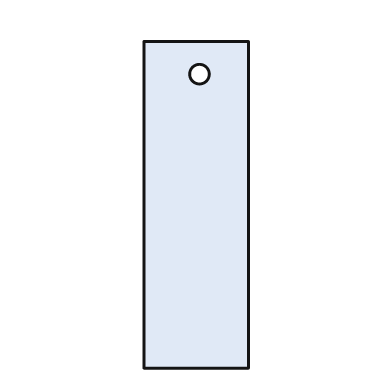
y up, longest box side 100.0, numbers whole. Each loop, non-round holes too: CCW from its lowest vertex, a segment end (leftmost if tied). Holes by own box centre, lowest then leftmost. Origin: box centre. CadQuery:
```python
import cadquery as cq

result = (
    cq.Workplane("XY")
    .moveTo(-16.0, -50.0)
    .lineTo(16.0, -50.0)
    .lineTo(16.0, 50.0)
    .lineTo(-16.0, 50.0)
    .close()
    .moveTo(1.0, 40.0)
    .circle(3.0)
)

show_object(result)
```